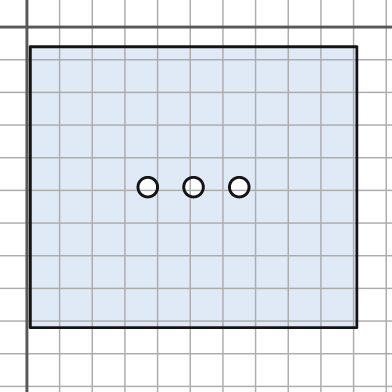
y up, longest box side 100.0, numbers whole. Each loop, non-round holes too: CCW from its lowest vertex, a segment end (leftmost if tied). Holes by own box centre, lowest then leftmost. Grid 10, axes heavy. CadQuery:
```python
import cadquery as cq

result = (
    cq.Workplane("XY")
    .moveTo(1.0, -92.0)
    .lineTo(101.0, -92.0)
    .lineTo(101.0, -6.0)
    .lineTo(1.0, -6.0)
    .close()
    .moveTo(37.0, -49.0)
    .circle(3.0)
    .moveTo(51.0, -49.0)
    .circle(3.0)
    .moveTo(65.0, -49.0)
    .circle(3.0)
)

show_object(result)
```